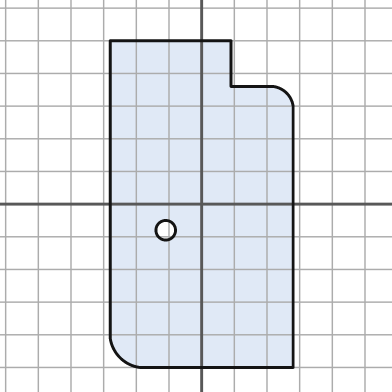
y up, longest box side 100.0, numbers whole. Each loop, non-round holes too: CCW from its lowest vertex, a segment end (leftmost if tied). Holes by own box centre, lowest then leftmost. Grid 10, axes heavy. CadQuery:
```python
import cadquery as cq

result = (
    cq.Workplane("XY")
    .moveTo(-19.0, -50.0)
    .lineTo(28.0, -50.0)
    .lineTo(28.0, 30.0)
    .threePointArc((26.0, 34.0), (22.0, 36.0))
    .lineTo(9.0, 36.0)
    .lineTo(9.0, 50.0)
    .lineTo(-28.0, 50.0)
    .lineTo(-28.0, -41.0)
    .threePointArc((-25.0, -47.0), (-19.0, -50.0))
    .close()
    .moveTo(-11.0, -8.0)
    .circle(3.0)
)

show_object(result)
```